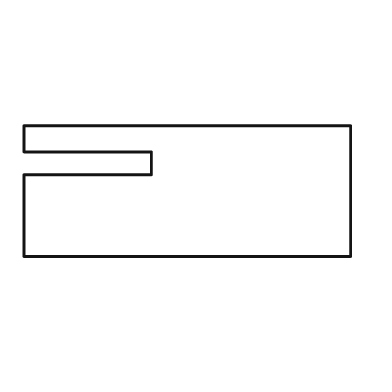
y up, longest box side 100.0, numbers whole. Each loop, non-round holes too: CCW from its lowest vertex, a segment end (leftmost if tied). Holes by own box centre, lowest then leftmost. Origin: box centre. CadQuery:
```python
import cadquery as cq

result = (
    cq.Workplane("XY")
    .moveTo(-50.0, -20.0)
    .lineTo(50.0, -20.0)
    .lineTo(50.0, 20.0)
    .lineTo(-50.0, 20.0)
    .lineTo(-50.0, 12.0)
    .lineTo(-11.0, 12.0)
    .lineTo(-11.0, 5.0)
    .lineTo(-50.0, 5.0)
    .close()
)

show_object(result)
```